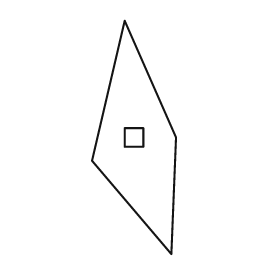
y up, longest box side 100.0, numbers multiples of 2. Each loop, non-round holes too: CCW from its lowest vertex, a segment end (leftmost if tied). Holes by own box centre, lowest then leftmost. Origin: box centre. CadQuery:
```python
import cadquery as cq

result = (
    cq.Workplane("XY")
    .moveTo(16.0, -50.0)
    .lineTo(18.0, 0.0)
    .lineTo(-4.0, 50.0)
    .lineTo(-18.0, -10.0)
    .close()
    .moveTo(-4.0, -4.0)
    .lineTo(4.0, -4.0)
    .lineTo(4.0, 4.0)
    .lineTo(-4.0, 4.0)
    .close()
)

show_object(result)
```